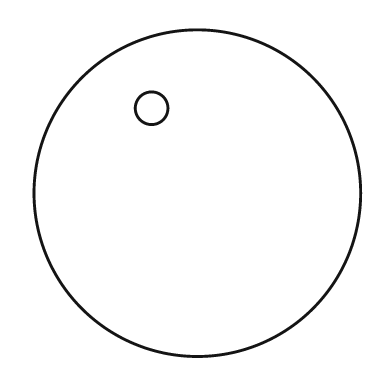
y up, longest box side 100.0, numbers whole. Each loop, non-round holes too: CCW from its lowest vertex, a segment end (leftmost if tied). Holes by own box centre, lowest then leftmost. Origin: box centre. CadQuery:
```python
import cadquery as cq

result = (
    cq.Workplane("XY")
    .moveTo(0.0, 0.0)
    .circle(50.0)
    .moveTo(-14.0, 26.0)
    .circle(5.0)
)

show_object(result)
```